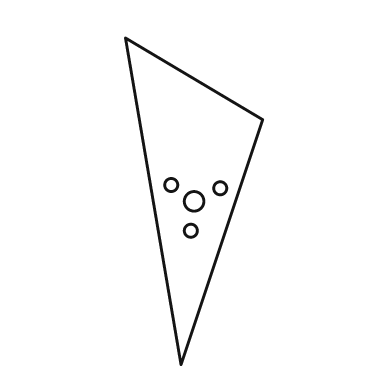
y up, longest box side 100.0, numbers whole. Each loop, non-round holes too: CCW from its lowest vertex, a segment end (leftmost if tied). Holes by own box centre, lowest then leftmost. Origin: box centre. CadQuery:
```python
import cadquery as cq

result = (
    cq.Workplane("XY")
    .moveTo(-4.0, -50.0)
    .lineTo(21.0, 25.0)
    .lineTo(-21.0, 50.0)
    .close()
    .moveTo(-1.0, -9.0)
    .circle(2.0)
    .moveTo(0.0, 0.0)
    .circle(3.0)
    .moveTo(8.0, 4.0)
    .circle(2.0)
    .moveTo(-7.0, 5.0)
    .circle(2.0)
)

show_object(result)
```